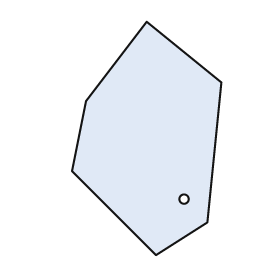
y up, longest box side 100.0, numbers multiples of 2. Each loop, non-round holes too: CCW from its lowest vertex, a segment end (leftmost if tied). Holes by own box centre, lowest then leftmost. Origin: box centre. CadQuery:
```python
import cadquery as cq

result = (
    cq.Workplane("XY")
    .moveTo(4.0, -50.0)
    .lineTo(26.0, -36.0)
    .lineTo(32.0, 24.0)
    .lineTo(0.0, 50.0)
    .lineTo(-26.0, 16.0)
    .lineTo(-32.0, -14.0)
    .close()
    .moveTo(16.0, -26.0)
    .circle(2.0)
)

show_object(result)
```